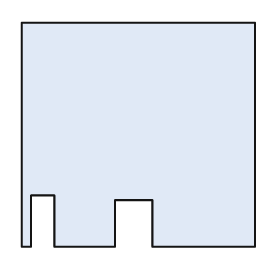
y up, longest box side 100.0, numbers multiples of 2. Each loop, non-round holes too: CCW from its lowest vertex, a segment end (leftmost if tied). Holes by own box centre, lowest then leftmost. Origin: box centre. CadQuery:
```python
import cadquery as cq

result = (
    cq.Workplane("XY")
    .moveTo(-50.0, -48.0)
    .lineTo(-46.0, -48.0)
    .lineTo(-46.0, -26.0)
    .lineTo(-36.0, -26.0)
    .lineTo(-36.0, -48.0)
    .lineTo(-10.0, -48.0)
    .lineTo(-10.0, -28.0)
    .lineTo(6.0, -28.0)
    .lineTo(6.0, -48.0)
    .lineTo(50.0, -48.0)
    .lineTo(50.0, 48.0)
    .lineTo(-50.0, 48.0)
    .close()
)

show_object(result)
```